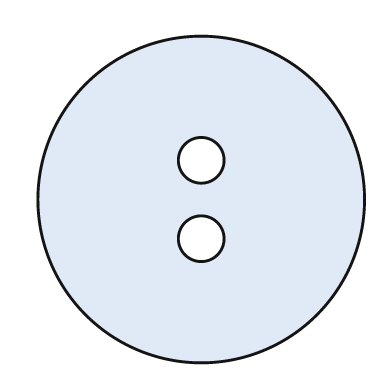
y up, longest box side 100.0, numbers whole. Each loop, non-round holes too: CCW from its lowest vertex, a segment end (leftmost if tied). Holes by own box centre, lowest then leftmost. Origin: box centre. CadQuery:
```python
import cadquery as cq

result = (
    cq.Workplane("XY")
    .moveTo(0.0, 0.0)
    .circle(50.0)
    .moveTo(0.0, -12.0)
    .circle(7.0)
    .moveTo(0.0, 12.0)
    .circle(7.0)
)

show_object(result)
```